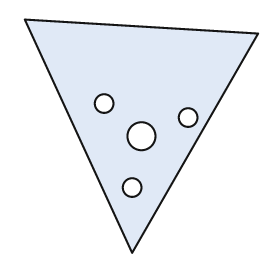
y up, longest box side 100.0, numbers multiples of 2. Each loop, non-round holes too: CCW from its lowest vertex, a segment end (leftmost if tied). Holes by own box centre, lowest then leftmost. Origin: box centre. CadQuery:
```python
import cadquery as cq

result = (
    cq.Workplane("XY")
    .moveTo(-4.0, -50.0)
    .lineTo(50.0, 44.0)
    .lineTo(-50.0, 50.0)
    .close()
    .moveTo(-4.0, -22.0)
    .circle(4.0)
    .moveTo(0.0, 0.0)
    .circle(6.0)
    .moveTo(20.0, 8.0)
    .circle(4.0)
    .moveTo(-16.0, 14.0)
    .circle(4.0)
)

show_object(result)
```